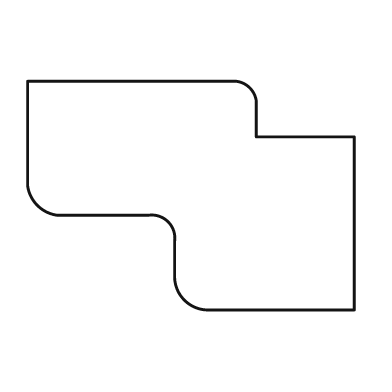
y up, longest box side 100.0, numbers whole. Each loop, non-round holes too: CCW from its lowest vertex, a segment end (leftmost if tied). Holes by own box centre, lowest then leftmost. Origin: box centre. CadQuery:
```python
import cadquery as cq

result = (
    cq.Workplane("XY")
    .moveTo(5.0, -35.0)
    .lineTo(50.0, -35.0)
    .lineTo(50.0, 18.0)
    .lineTo(20.0, 18.0)
    .lineTo(20.0, 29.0)
    .threePointArc((18.0, 33.0), (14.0, 35.0))
    .lineTo(-50.0, 35.0)
    .lineTo(-50.0, 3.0)
    .threePointArc((-47.0, -3.0), (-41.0, -6.0))
    .lineTo(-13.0, -6.0)
    .threePointArc((-7.0, -8.0), (-5.0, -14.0))
    .lineTo(-5.0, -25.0)
    .threePointArc((-2.0, -32.0), (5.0, -35.0))
    .close()
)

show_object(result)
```